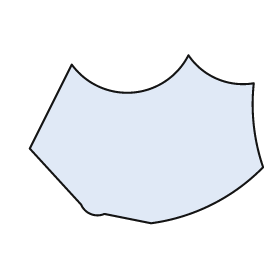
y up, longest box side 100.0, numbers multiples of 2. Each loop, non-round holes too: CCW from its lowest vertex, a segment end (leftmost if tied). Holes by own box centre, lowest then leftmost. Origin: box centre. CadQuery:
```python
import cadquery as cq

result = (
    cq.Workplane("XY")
    .moveTo(2.0, -36.0)
    .threePointArc((28.0, -28.0), (50.0, -12.0))
    .threePointArc((46.0, 6.0), (46.0, 24.0))
    .threePointArc((30.0, 26.0), (18.0, 36.0))
    .threePointArc((-6.0, 20.0), (-32.0, 32.0))
    .lineTo(-50.0, -4.0)
    .lineTo(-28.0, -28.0)
    .threePointArc((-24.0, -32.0), (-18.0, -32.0))
    .close()
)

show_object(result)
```